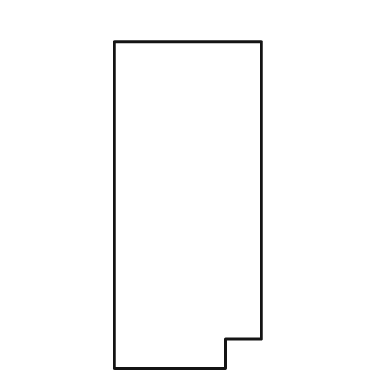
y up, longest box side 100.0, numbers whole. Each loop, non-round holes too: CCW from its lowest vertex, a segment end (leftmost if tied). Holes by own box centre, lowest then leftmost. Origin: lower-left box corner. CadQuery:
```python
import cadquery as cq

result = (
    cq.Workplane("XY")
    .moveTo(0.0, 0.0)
    .lineTo(34.0, 0.0)
    .lineTo(34.0, 9.0)
    .lineTo(45.0, 9.0)
    .lineTo(45.0, 100.0)
    .lineTo(0.0, 100.0)
    .close()
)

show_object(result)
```